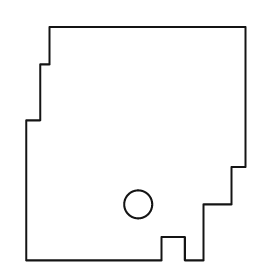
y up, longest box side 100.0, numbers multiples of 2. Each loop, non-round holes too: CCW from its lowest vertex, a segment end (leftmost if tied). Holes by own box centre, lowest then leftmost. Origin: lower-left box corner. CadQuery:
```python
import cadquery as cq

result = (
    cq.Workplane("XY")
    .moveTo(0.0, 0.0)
    .lineTo(58.0, 0.0)
    .lineTo(58.0, 10.0)
    .lineTo(68.0, 10.0)
    .lineTo(68.0, 0.0)
    .lineTo(76.0, 0.0)
    .lineTo(76.0, 24.0)
    .lineTo(88.0, 24.0)
    .lineTo(88.0, 40.0)
    .lineTo(94.0, 40.0)
    .lineTo(94.0, 100.0)
    .lineTo(10.0, 100.0)
    .lineTo(10.0, 84.0)
    .lineTo(6.0, 84.0)
    .lineTo(6.0, 60.0)
    .lineTo(0.0, 60.0)
    .close()
    .moveTo(48.0, 24.0)
    .circle(6.0)
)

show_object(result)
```